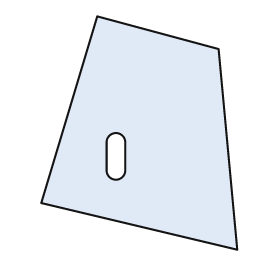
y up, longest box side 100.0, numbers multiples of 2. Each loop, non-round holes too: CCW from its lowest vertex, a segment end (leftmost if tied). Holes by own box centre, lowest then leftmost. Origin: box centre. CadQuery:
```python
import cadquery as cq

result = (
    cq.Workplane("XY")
    .moveTo(42.0, -50.0)
    .lineTo(34.0, 36.0)
    .lineTo(-18.0, 50.0)
    .lineTo(-42.0, -30.0)
    .close()
    .moveTo(-14.0, -16.0)
    .threePointArc((-10.0, -20.0), (-6.0, -16.0))
    .lineTo(-6.0, -4.0)
    .threePointArc((-10.0, 0.0), (-14.0, -4.0))
    .close()
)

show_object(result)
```